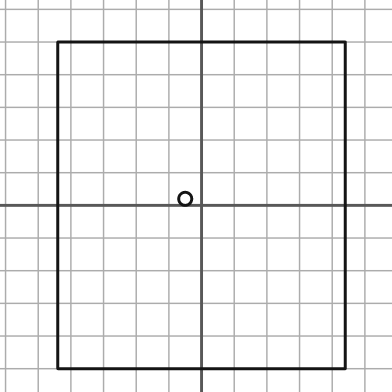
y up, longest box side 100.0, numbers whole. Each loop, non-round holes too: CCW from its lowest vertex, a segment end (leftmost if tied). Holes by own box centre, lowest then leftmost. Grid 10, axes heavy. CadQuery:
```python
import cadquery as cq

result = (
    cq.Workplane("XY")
    .moveTo(-44.0, -50.0)
    .lineTo(44.0, -50.0)
    .lineTo(44.0, 50.0)
    .lineTo(-44.0, 50.0)
    .close()
    .moveTo(-5.0, 2.0)
    .circle(2.0)
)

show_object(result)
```